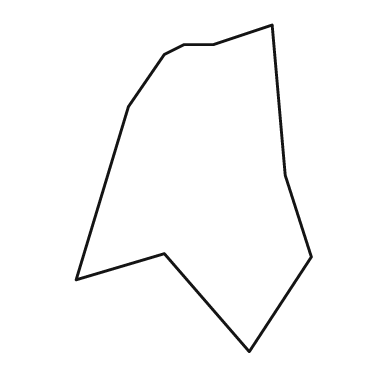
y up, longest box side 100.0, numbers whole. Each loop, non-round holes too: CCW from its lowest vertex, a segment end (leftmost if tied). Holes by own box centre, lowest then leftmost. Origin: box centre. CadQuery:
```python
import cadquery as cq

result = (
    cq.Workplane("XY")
    .moveTo(17.0, -50.0)
    .lineTo(36.0, -21.0)
    .lineTo(28.0, 4.0)
    .lineTo(24.0, 50.0)
    .lineTo(6.0, 44.0)
    .lineTo(-3.0, 44.0)
    .lineTo(-9.0, 41.0)
    .lineTo(-20.0, 25.0)
    .lineTo(-36.0, -28.0)
    .lineTo(-9.0, -20.0)
    .close()
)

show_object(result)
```